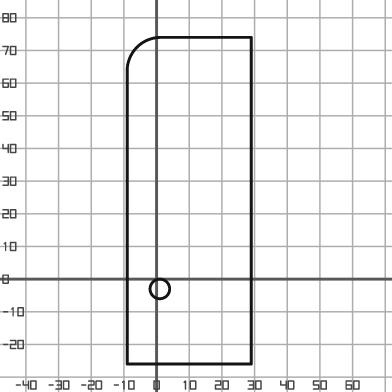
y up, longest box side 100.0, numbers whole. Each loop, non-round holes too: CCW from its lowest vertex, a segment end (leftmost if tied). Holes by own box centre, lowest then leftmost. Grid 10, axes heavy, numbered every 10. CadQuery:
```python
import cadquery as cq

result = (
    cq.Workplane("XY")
    .moveTo(-9.0, -26.0)
    .lineTo(29.0, -26.0)
    .lineTo(29.0, 74.0)
    .lineTo(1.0, 74.0)
    .threePointArc((-6.0, 71.0), (-9.0, 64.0))
    .close()
    .moveTo(1.0, -3.0)
    .circle(3.0)
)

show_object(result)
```